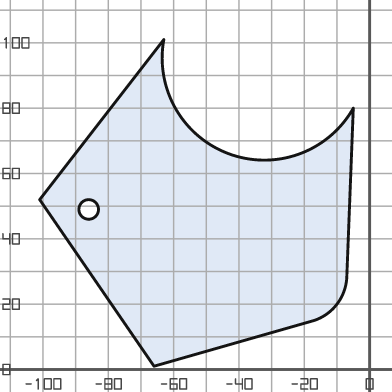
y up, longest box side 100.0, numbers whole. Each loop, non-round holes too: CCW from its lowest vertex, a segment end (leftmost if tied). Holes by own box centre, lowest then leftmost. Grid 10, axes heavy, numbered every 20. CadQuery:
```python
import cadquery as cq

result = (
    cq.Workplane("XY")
    .moveTo(-66.0, 1.0)
    .lineTo(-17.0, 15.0)
    .threePointArc((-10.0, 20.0), (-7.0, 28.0))
    .lineTo(-5.0, 80.0)
    .threePointArc((-43.0, 66.0), (-63.0, 101.0))
    .lineTo(-101.0, 52.0)
    .close()
    .moveTo(-86.0, 49.0)
    .circle(3.0)
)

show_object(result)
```